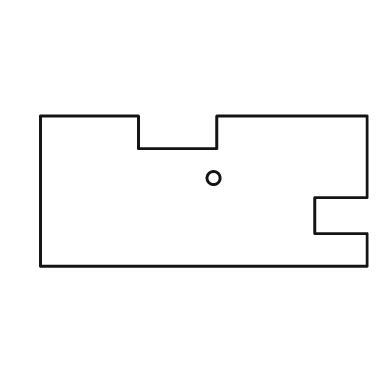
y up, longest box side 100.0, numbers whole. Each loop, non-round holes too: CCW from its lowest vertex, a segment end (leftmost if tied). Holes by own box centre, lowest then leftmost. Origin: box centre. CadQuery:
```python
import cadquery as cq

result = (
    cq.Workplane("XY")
    .moveTo(-50.0, -23.0)
    .lineTo(50.0, -23.0)
    .lineTo(50.0, -13.0)
    .lineTo(34.0, -13.0)
    .lineTo(34.0, -2.0)
    .lineTo(50.0, -2.0)
    .lineTo(50.0, 23.0)
    .lineTo(4.0, 23.0)
    .lineTo(4.0, 13.0)
    .lineTo(-20.0, 13.0)
    .lineTo(-20.0, 23.0)
    .lineTo(-50.0, 23.0)
    .close()
    .moveTo(3.0, 4.0)
    .circle(2.0)
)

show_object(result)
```